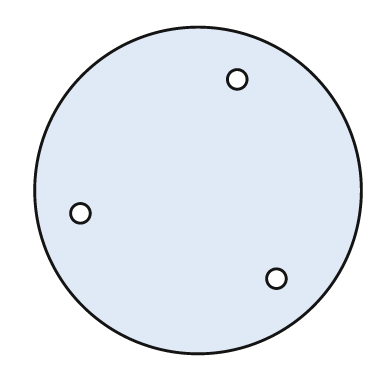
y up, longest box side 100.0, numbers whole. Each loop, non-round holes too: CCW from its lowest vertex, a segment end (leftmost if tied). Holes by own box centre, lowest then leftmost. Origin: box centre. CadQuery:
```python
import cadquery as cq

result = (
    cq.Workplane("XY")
    .moveTo(0.0, 0.0)
    .circle(50.0)
    .moveTo(24.0, -27.0)
    .circle(3.0)
    .moveTo(-36.0, -7.0)
    .circle(3.0)
    .moveTo(12.0, 34.0)
    .circle(3.0)
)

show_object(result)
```